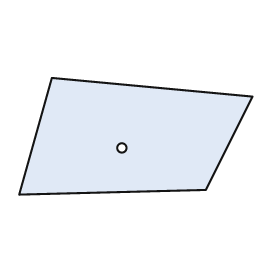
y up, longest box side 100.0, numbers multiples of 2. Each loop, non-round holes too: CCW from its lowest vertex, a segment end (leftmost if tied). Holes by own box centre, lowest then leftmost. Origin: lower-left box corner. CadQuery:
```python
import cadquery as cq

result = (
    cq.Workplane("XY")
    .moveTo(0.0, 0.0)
    .lineTo(80.0, 2.0)
    .lineTo(100.0, 42.0)
    .lineTo(14.0, 50.0)
    .close()
    .moveTo(44.0, 20.0)
    .circle(2.0)
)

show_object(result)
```